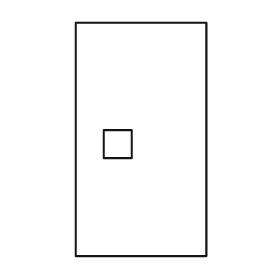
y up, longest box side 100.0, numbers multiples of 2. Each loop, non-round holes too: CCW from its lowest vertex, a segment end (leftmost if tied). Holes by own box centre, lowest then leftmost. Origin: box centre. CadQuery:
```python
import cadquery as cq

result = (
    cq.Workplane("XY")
    .moveTo(-28.0, -50.0)
    .lineTo(28.0, -50.0)
    .lineTo(28.0, 50.0)
    .lineTo(-28.0, 50.0)
    .close()
    .moveTo(-16.0, -8.0)
    .lineTo(-4.0, -8.0)
    .lineTo(-4.0, 4.0)
    .lineTo(-16.0, 4.0)
    .close()
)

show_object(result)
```